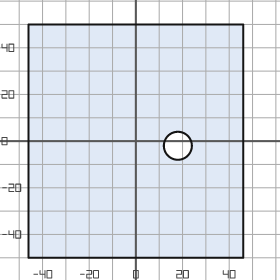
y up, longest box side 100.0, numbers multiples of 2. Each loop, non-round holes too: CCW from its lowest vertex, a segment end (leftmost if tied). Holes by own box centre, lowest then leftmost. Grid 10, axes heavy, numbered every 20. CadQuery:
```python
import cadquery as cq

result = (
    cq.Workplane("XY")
    .moveTo(-46.0, -50.0)
    .lineTo(46.0, -50.0)
    .lineTo(46.0, 50.0)
    .lineTo(-46.0, 50.0)
    .close()
    .moveTo(18.0, -2.0)
    .circle(6.0)
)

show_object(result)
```